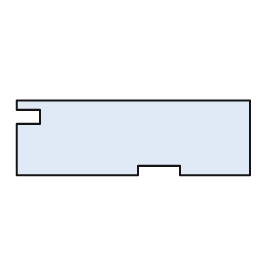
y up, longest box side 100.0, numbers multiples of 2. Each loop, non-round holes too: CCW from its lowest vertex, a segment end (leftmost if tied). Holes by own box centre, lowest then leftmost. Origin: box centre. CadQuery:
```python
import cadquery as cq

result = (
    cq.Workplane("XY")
    .moveTo(-50.0, -16.0)
    .lineTo(2.0, -16.0)
    .lineTo(2.0, -12.0)
    .lineTo(20.0, -12.0)
    .lineTo(20.0, -16.0)
    .lineTo(50.0, -16.0)
    .lineTo(50.0, 16.0)
    .lineTo(-50.0, 16.0)
    .lineTo(-50.0, 12.0)
    .lineTo(-40.0, 12.0)
    .lineTo(-40.0, 6.0)
    .lineTo(-50.0, 6.0)
    .close()
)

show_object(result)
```